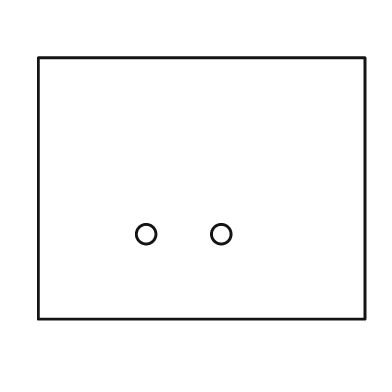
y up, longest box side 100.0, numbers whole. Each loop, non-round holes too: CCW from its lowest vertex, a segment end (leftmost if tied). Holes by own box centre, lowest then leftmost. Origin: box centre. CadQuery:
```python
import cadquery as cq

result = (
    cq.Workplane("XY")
    .moveTo(-50.0, -40.0)
    .lineTo(50.0, -40.0)
    .lineTo(50.0, 40.0)
    .lineTo(-50.0, 40.0)
    .close()
    .moveTo(-17.0, -14.0)
    .circle(3.0)
    .moveTo(6.0, -14.0)
    .circle(3.0)
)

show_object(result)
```